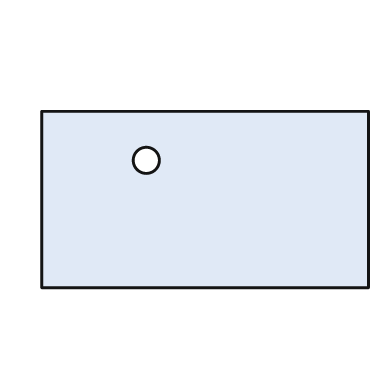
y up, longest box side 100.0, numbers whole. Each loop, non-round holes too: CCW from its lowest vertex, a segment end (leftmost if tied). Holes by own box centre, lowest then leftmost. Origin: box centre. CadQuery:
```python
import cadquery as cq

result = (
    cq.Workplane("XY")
    .moveTo(-50.0, -27.0)
    .lineTo(50.0, -27.0)
    .lineTo(50.0, 27.0)
    .lineTo(-50.0, 27.0)
    .close()
    .moveTo(-18.0, 12.0)
    .circle(4.0)
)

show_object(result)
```